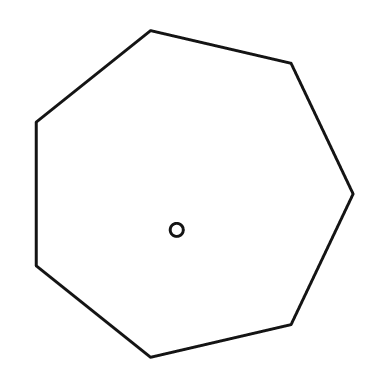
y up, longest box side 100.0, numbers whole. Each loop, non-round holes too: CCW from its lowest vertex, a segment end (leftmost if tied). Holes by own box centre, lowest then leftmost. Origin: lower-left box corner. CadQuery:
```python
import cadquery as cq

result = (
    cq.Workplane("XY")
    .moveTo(35.0, 0.0)
    .lineTo(78.0, 10.0)
    .lineTo(97.0, 50.0)
    .lineTo(78.0, 90.0)
    .lineTo(35.0, 100.0)
    .lineTo(0.0, 72.0)
    .lineTo(0.0, 28.0)
    .close()
    .moveTo(43.0, 39.0)
    .circle(2.0)
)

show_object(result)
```